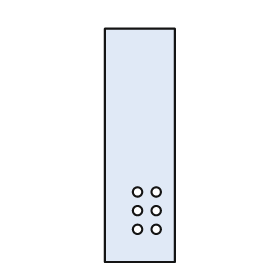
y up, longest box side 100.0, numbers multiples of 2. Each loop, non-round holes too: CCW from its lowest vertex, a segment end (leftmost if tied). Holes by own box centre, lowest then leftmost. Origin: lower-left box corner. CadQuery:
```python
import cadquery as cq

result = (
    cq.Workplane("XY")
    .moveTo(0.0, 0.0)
    .lineTo(30.0, 0.0)
    .lineTo(30.0, 100.0)
    .lineTo(0.0, 100.0)
    .close()
    .moveTo(14.0, 14.0)
    .circle(2.0)
    .moveTo(22.0, 14.0)
    .circle(2.0)
    .moveTo(14.0, 22.0)
    .circle(2.0)
    .moveTo(22.0, 22.0)
    .circle(2.0)
    .moveTo(14.0, 30.0)
    .circle(2.0)
    .moveTo(22.0, 30.0)
    .circle(2.0)
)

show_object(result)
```